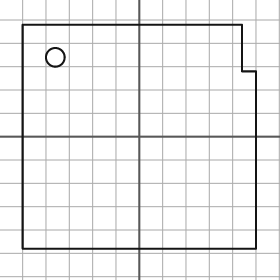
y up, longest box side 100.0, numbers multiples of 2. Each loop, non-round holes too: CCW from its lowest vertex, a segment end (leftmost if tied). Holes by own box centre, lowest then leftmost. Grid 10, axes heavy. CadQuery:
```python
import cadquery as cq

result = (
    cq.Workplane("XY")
    .moveTo(-50.0, -48.0)
    .lineTo(50.0, -48.0)
    .lineTo(50.0, 28.0)
    .lineTo(44.0, 28.0)
    .lineTo(44.0, 48.0)
    .lineTo(-50.0, 48.0)
    .close()
    .moveTo(-36.0, 34.0)
    .circle(4.0)
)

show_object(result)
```